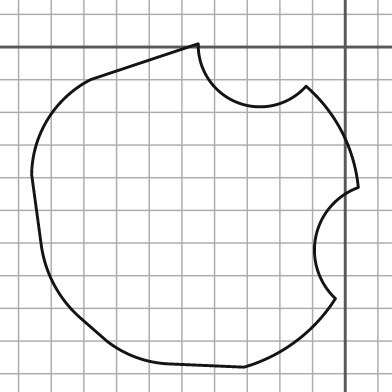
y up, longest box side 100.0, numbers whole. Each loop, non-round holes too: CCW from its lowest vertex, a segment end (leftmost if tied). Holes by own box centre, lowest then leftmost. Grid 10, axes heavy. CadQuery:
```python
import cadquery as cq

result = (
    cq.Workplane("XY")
    .moveTo(-31.0, -98.0)
    .threePointArc((-15.0, -90.0), (-3.0, -77.0))
    .threePointArc((-9.0, -58.0), (4.0, -43.0))
    .threePointArc((-1.0, -26.0), (-12.0, -12.0))
    .threePointArc((-33.0, -17.0), (-45.0, 1.0))
    .lineTo(-78.0, -10.0)
    .threePointArc((-91.0, -22.0), (-96.0, -39.0))
    .lineTo(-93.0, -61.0)
    .threePointArc((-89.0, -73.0), (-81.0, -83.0))
    .lineTo(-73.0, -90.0)
    .threePointArc((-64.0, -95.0), (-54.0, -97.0))
    .close()
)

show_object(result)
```